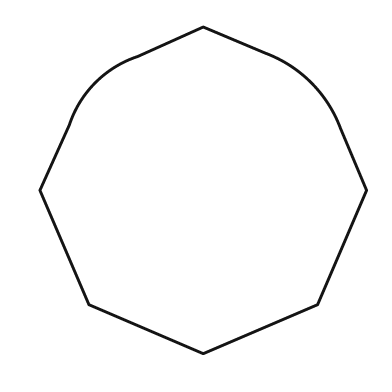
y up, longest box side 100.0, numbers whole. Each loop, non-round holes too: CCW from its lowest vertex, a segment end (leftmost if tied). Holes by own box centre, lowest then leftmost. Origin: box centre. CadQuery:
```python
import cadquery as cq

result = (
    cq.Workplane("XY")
    .moveTo(0.0, -50.0)
    .lineTo(35.0, -35.0)
    .lineTo(50.0, 0.0)
    .lineTo(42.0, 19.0)
    .threePointArc((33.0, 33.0), (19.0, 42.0))
    .lineTo(0.0, 50.0)
    .lineTo(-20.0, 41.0)
    .threePointArc((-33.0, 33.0), (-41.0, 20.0))
    .lineTo(-50.0, 0.0)
    .lineTo(-35.0, -35.0)
    .close()
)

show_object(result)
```